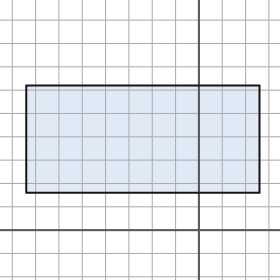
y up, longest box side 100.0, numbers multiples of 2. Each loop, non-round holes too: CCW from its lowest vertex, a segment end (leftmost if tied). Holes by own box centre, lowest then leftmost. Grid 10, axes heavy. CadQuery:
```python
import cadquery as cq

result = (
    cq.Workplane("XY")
    .moveTo(-74.0, 16.0)
    .lineTo(26.0, 16.0)
    .lineTo(26.0, 62.0)
    .lineTo(-74.0, 62.0)
    .close()
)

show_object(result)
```